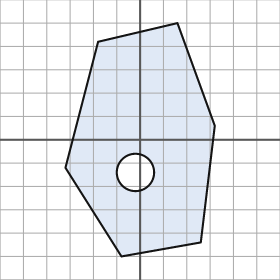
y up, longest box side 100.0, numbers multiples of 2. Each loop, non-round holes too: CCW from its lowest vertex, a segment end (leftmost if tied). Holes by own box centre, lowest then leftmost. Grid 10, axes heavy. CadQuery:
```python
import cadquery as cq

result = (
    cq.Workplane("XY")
    .moveTo(-8.0, -50.0)
    .lineTo(26.0, -44.0)
    .lineTo(32.0, 6.0)
    .lineTo(16.0, 50.0)
    .lineTo(-18.0, 42.0)
    .lineTo(-32.0, -12.0)
    .close()
    .moveTo(-2.0, -14.0)
    .circle(8.0)
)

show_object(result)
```